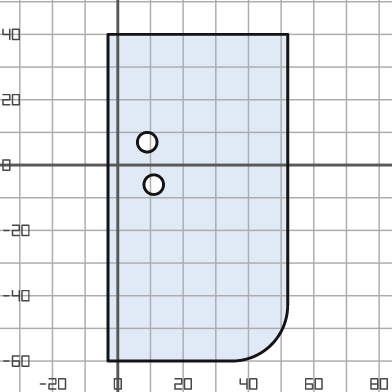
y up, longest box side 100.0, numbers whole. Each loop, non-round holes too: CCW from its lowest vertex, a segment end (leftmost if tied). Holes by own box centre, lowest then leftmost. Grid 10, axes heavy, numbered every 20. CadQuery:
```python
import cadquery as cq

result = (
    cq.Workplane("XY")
    .moveTo(-3.0, -60.0)
    .lineTo(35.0, -60.0)
    .threePointArc((47.0, -55.0), (52.0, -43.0))
    .lineTo(52.0, 40.0)
    .lineTo(-3.0, 40.0)
    .close()
    .moveTo(11.0, -6.0)
    .circle(3.0)
    .moveTo(9.0, 7.0)
    .circle(3.0)
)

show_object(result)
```